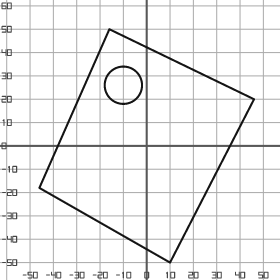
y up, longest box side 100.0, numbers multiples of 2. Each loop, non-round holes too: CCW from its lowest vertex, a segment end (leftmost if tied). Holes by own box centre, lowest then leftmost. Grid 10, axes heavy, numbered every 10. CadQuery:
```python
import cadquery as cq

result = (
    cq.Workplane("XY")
    .moveTo(10.0, -50.0)
    .lineTo(46.0, 20.0)
    .lineTo(-16.0, 50.0)
    .lineTo(-46.0, -18.0)
    .close()
    .moveTo(-10.0, 26.0)
    .circle(8.0)
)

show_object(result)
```